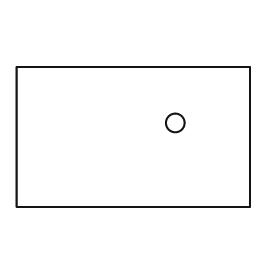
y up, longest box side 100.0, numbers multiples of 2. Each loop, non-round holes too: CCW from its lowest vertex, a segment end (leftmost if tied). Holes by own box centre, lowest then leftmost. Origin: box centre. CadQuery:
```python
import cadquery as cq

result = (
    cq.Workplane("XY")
    .moveTo(-50.0, -30.0)
    .lineTo(50.0, -30.0)
    .lineTo(50.0, 30.0)
    .lineTo(-50.0, 30.0)
    .close()
    .moveTo(18.0, 6.0)
    .circle(4.0)
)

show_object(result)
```